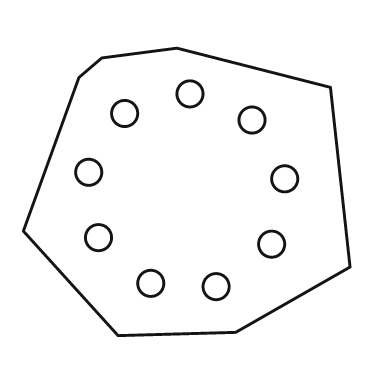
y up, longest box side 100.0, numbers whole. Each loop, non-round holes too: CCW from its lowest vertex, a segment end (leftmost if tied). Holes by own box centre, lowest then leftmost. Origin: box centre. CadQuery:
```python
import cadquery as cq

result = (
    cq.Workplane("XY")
    .moveTo(-21.0, -44.0)
    .lineTo(15.0, -43.0)
    .lineTo(50.0, -23.0)
    .lineTo(44.0, 32.0)
    .lineTo(-3.0, 44.0)
    .lineTo(-26.0, 41.0)
    .lineTo(-33.0, 35.0)
    .lineTo(-50.0, -12.0)
    .close()
    .moveTo(9.0, -29.0)
    .circle(4.0)
    .moveTo(-11.0, -28.0)
    .circle(4.0)
    .moveTo(26.0, -16.0)
    .circle(4.0)
    .moveTo(-27.0, -14.0)
    .circle(4.0)
    .moveTo(30.0, 4.0)
    .circle(4.0)
    .moveTo(-30.0, 6.0)
    .circle(4.0)
    .moveTo(20.0, 22.0)
    .circle(4.0)
    .moveTo(-19.0, 24.0)
    .circle(4.0)
    .moveTo(1.0, 30.0)
    .circle(4.0)
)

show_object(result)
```